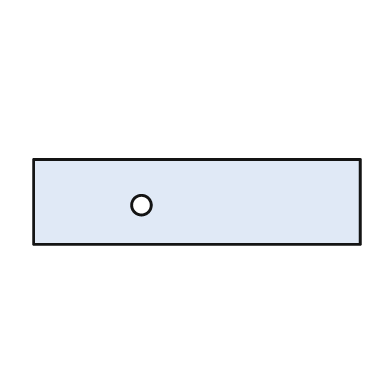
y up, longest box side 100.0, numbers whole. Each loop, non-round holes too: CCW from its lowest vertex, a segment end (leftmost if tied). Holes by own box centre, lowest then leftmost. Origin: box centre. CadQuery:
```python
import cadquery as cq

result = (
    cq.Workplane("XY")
    .moveTo(-50.0, -13.0)
    .lineTo(50.0, -13.0)
    .lineTo(50.0, 13.0)
    .lineTo(-50.0, 13.0)
    .close()
    .moveTo(-17.0, -1.0)
    .circle(3.0)
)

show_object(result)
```